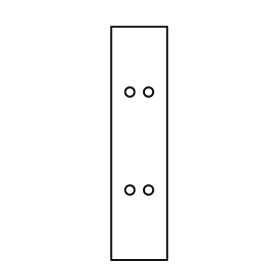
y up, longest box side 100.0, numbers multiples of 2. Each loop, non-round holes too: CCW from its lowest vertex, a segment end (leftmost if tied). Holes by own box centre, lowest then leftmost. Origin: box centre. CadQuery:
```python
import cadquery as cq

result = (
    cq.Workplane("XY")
    .moveTo(-12.0, -50.0)
    .lineTo(12.0, -50.0)
    .lineTo(12.0, 50.0)
    .lineTo(-12.0, 50.0)
    .close()
    .moveTo(-4.0, -20.0)
    .circle(2.0)
    .moveTo(4.0, -20.0)
    .circle(2.0)
    .moveTo(-4.0, 22.0)
    .circle(2.0)
    .moveTo(4.0, 22.0)
    .circle(2.0)
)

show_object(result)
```